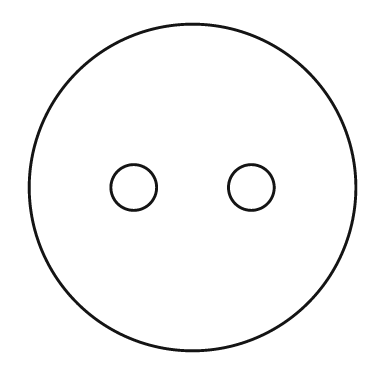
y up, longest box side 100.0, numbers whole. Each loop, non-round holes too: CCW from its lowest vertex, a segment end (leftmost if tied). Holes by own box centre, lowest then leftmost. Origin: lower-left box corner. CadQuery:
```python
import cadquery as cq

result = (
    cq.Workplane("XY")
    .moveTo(50.0, 50.0)
    .circle(50.0)
    .moveTo(32.0, 50.0)
    .circle(7.0)
    .moveTo(68.0, 50.0)
    .circle(7.0)
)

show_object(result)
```